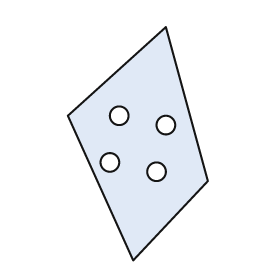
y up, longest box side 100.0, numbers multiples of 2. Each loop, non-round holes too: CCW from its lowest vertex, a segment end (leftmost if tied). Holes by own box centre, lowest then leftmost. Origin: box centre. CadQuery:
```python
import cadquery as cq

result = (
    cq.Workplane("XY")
    .moveTo(-2.0, -50.0)
    .lineTo(30.0, -16.0)
    .lineTo(12.0, 50.0)
    .lineTo(-30.0, 12.0)
    .close()
    .moveTo(8.0, -12.0)
    .circle(4.0)
    .moveTo(-12.0, -8.0)
    .circle(4.0)
    .moveTo(12.0, 8.0)
    .circle(4.0)
    .moveTo(-8.0, 12.0)
    .circle(4.0)
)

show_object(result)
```